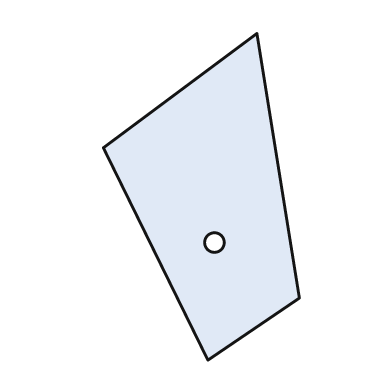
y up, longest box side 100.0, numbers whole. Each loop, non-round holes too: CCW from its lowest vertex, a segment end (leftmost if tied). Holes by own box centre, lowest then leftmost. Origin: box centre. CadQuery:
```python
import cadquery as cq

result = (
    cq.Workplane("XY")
    .moveTo(2.0, -50.0)
    .lineTo(30.0, -31.0)
    .lineTo(17.0, 50.0)
    .lineTo(-30.0, 15.0)
    .close()
    .moveTo(4.0, -14.0)
    .circle(3.0)
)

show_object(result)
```